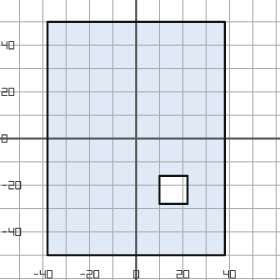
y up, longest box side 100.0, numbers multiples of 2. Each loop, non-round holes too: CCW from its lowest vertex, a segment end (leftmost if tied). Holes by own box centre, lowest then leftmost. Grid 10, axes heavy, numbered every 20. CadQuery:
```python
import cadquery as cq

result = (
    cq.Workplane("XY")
    .moveTo(-38.0, -50.0)
    .lineTo(38.0, -50.0)
    .lineTo(38.0, 50.0)
    .lineTo(-38.0, 50.0)
    .close()
    .moveTo(10.0, -28.0)
    .lineTo(22.0, -28.0)
    .lineTo(22.0, -16.0)
    .lineTo(10.0, -16.0)
    .close()
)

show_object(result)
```